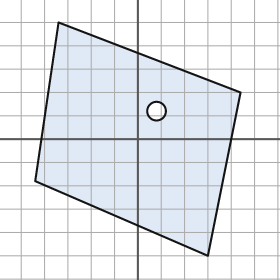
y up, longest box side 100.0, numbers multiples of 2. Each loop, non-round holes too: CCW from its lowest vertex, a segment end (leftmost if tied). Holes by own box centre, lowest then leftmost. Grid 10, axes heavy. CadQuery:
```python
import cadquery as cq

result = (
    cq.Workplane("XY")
    .moveTo(30.0, -50.0)
    .lineTo(44.0, 20.0)
    .lineTo(-34.0, 50.0)
    .lineTo(-44.0, -18.0)
    .close()
    .moveTo(8.0, 12.0)
    .circle(4.0)
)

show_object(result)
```